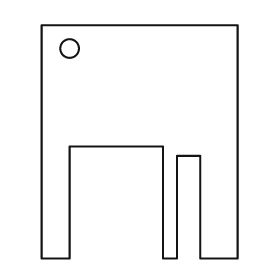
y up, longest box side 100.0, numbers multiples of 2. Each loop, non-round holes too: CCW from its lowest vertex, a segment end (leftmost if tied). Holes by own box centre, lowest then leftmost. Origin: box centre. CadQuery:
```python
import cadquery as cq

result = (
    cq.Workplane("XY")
    .moveTo(-42.0, -50.0)
    .lineTo(-30.0, -50.0)
    .lineTo(-30.0, -2.0)
    .lineTo(10.0, -2.0)
    .lineTo(10.0, -50.0)
    .lineTo(16.0, -50.0)
    .lineTo(16.0, -6.0)
    .lineTo(26.0, -6.0)
    .lineTo(26.0, -50.0)
    .lineTo(42.0, -50.0)
    .lineTo(42.0, 50.0)
    .lineTo(-42.0, 50.0)
    .close()
    .moveTo(-30.0, 40.0)
    .circle(4.0)
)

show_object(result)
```